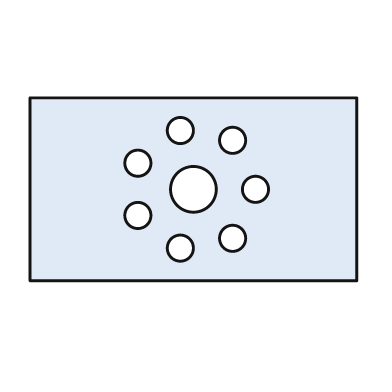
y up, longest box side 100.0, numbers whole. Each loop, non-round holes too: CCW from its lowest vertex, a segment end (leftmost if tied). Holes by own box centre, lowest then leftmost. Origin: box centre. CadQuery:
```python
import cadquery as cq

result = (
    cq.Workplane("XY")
    .moveTo(-50.0, -28.0)
    .lineTo(50.0, -28.0)
    .lineTo(50.0, 28.0)
    .lineTo(-50.0, 28.0)
    .close()
    .moveTo(-4.0, -18.0)
    .circle(4.0)
    .moveTo(12.0, -15.0)
    .circle(4.0)
    .moveTo(-17.0, -8.0)
    .circle(4.0)
    .moveTo(0.0, 0.0)
    .circle(7.0)
    .moveTo(19.0, 0.0)
    .circle(4.0)
    .moveTo(-17.0, 8.0)
    .circle(4.0)
    .moveTo(12.0, 15.0)
    .circle(4.0)
    .moveTo(-4.0, 18.0)
    .circle(4.0)
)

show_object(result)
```